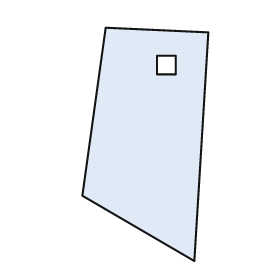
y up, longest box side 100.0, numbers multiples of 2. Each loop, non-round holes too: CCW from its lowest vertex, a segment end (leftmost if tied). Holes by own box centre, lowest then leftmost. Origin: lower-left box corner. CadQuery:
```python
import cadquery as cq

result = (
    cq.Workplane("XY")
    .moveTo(48.0, 0.0)
    .lineTo(54.0, 98.0)
    .lineTo(10.0, 100.0)
    .lineTo(0.0, 28.0)
    .close()
    .moveTo(32.0, 80.0)
    .lineTo(40.0, 80.0)
    .lineTo(40.0, 88.0)
    .lineTo(32.0, 88.0)
    .close()
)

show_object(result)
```